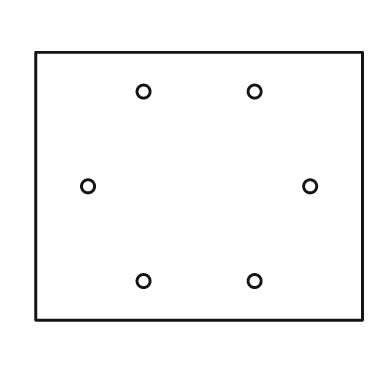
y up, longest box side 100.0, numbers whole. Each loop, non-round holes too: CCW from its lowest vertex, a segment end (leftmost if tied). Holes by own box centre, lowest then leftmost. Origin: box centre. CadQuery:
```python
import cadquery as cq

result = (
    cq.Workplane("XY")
    .moveTo(-50.0, -41.0)
    .lineTo(50.0, -41.0)
    .lineTo(50.0, 41.0)
    .lineTo(-50.0, 41.0)
    .close()
    .moveTo(-17.0, -29.0)
    .circle(2.0)
    .moveTo(17.0, -29.0)
    .circle(2.0)
    .moveTo(-34.0, 0.0)
    .circle(2.0)
    .moveTo(34.0, 0.0)
    .circle(2.0)
    .moveTo(-17.0, 29.0)
    .circle(2.0)
    .moveTo(17.0, 29.0)
    .circle(2.0)
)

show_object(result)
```